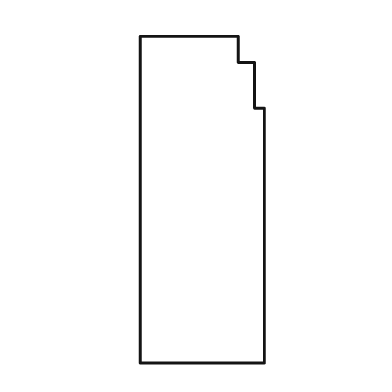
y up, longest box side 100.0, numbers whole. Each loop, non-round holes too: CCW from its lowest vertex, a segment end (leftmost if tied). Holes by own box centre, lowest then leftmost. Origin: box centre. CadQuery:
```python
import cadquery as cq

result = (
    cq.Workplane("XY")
    .moveTo(-19.0, -50.0)
    .lineTo(19.0, -50.0)
    .lineTo(19.0, 28.0)
    .lineTo(16.0, 28.0)
    .lineTo(16.0, 42.0)
    .lineTo(11.0, 42.0)
    .lineTo(11.0, 50.0)
    .lineTo(-19.0, 50.0)
    .close()
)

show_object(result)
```